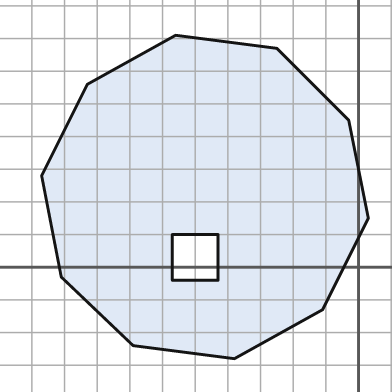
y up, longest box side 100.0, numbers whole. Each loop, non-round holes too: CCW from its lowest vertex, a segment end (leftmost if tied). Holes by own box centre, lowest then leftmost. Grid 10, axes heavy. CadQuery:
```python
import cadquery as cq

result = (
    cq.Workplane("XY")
    .moveTo(-38.0, -28.0)
    .lineTo(-11.0, -13.0)
    .lineTo(3.0, 15.0)
    .lineTo(-3.0, 45.0)
    .lineTo(-25.0, 67.0)
    .lineTo(-56.0, 71.0)
    .lineTo(-83.0, 56.0)
    .lineTo(-97.0, 28.0)
    .lineTo(-91.0, -3.0)
    .lineTo(-69.0, -24.0)
    .close()
    .moveTo(-57.0, -4.0)
    .lineTo(-43.0, -4.0)
    .lineTo(-43.0, 10.0)
    .lineTo(-57.0, 10.0)
    .close()
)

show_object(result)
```